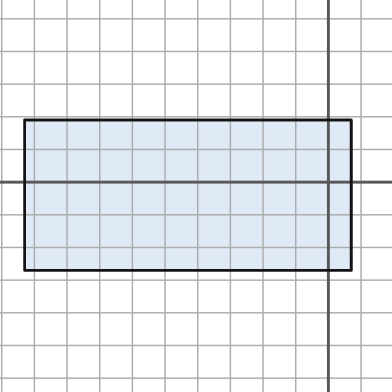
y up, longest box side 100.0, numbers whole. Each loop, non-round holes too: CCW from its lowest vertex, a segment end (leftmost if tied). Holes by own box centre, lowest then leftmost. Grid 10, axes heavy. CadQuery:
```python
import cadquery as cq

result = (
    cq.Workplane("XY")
    .moveTo(-93.0, -27.0)
    .lineTo(7.0, -27.0)
    .lineTo(7.0, 19.0)
    .lineTo(-93.0, 19.0)
    .close()
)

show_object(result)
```